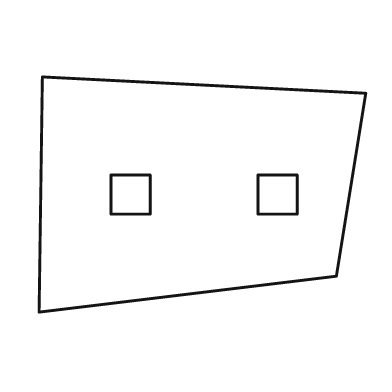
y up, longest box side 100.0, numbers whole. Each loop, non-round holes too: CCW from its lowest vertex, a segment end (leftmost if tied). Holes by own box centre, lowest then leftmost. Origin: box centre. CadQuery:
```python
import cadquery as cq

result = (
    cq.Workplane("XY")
    .moveTo(-50.0, -36.0)
    .lineTo(41.0, -25.0)
    .lineTo(50.0, 31.0)
    .lineTo(-49.0, 36.0)
    .close()
    .moveTo(-28.0, -6.0)
    .lineTo(-16.0, -6.0)
    .lineTo(-16.0, 6.0)
    .lineTo(-28.0, 6.0)
    .close()
    .moveTo(17.0, -6.0)
    .lineTo(29.0, -6.0)
    .lineTo(29.0, 6.0)
    .lineTo(17.0, 6.0)
    .close()
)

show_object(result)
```